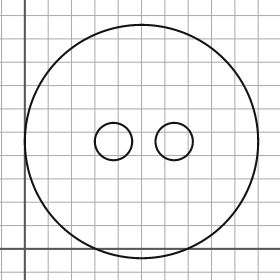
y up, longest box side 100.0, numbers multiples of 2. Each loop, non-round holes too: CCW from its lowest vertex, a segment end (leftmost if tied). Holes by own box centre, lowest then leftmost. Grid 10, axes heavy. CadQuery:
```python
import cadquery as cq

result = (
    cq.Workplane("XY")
    .moveTo(50.0, 46.0)
    .circle(50.0)
    .moveTo(38.0, 46.0)
    .circle(8.0)
    .moveTo(64.0, 46.0)
    .circle(8.0)
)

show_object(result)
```